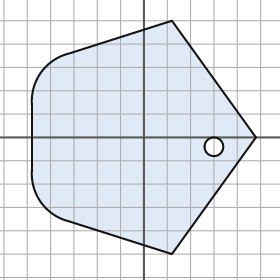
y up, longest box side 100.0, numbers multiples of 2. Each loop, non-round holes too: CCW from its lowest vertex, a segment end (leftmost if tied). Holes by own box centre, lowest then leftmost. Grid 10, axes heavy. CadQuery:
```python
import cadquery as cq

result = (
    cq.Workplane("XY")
    .moveTo(12.0, -50.0)
    .lineTo(48.0, 0.0)
    .lineTo(12.0, 50.0)
    .lineTo(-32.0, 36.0)
    .threePointArc((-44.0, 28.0), (-48.0, 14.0))
    .lineTo(-48.0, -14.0)
    .threePointArc((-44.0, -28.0), (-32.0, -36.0))
    .close()
    .moveTo(30.0, -4.0)
    .circle(4.0)
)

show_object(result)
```